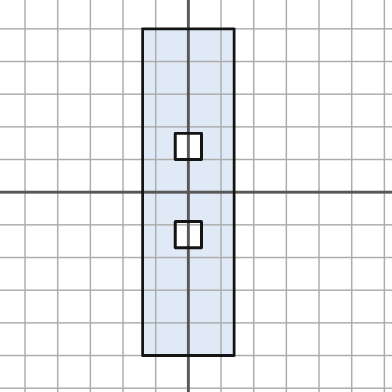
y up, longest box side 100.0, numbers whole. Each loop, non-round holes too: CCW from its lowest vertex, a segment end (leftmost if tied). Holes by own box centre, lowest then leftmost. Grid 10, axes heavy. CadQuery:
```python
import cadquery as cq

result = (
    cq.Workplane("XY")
    .moveTo(-14.0, -50.0)
    .lineTo(14.0, -50.0)
    .lineTo(14.0, 50.0)
    .lineTo(-14.0, 50.0)
    .close()
    .moveTo(-4.0, -17.0)
    .lineTo(4.0, -17.0)
    .lineTo(4.0, -9.0)
    .lineTo(-4.0, -9.0)
    .close()
    .moveTo(-4.0, 10.0)
    .lineTo(4.0, 10.0)
    .lineTo(4.0, 18.0)
    .lineTo(-4.0, 18.0)
    .close()
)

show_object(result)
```